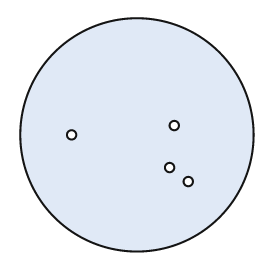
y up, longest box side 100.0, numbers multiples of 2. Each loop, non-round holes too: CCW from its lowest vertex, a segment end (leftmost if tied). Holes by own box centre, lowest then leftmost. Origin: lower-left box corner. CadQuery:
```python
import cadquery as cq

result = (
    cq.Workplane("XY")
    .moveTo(50.0, 50.0)
    .circle(50.0)
    .moveTo(72.0, 30.0)
    .circle(2.0)
    .moveTo(64.0, 36.0)
    .circle(2.0)
    .moveTo(22.0, 50.0)
    .circle(2.0)
    .moveTo(66.0, 54.0)
    .circle(2.0)
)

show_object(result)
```